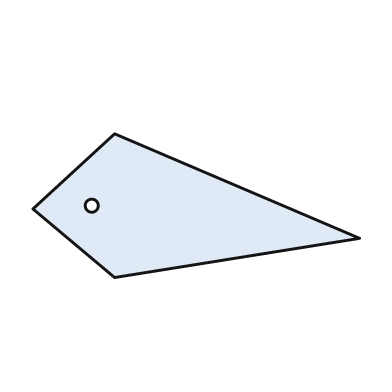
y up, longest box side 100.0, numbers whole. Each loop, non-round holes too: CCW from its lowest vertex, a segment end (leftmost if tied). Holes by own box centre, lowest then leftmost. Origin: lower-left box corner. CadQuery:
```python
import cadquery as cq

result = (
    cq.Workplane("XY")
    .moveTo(25.0, 0.0)
    .lineTo(100.0, 12.0)
    .lineTo(25.0, 44.0)
    .lineTo(0.0, 21.0)
    .close()
    .moveTo(18.0, 22.0)
    .circle(2.0)
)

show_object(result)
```